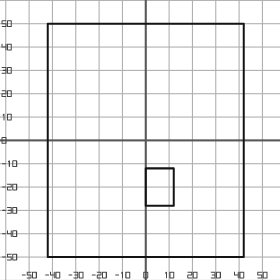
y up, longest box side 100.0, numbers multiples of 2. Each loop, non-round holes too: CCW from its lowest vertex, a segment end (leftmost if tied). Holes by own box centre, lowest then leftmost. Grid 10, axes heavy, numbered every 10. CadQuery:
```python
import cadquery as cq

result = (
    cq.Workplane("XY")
    .moveTo(-42.0, -50.0)
    .lineTo(42.0, -50.0)
    .lineTo(42.0, 50.0)
    .lineTo(-42.0, 50.0)
    .close()
    .moveTo(0.0, -28.0)
    .lineTo(12.0, -28.0)
    .lineTo(12.0, -12.0)
    .lineTo(0.0, -12.0)
    .close()
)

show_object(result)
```